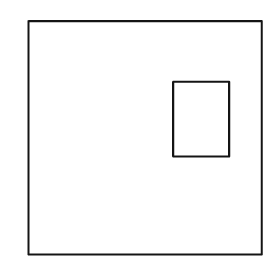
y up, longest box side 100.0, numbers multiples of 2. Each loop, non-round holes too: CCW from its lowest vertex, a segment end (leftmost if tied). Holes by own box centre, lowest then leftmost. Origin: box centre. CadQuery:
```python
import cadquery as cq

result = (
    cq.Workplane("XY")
    .moveTo(-50.0, -50.0)
    .lineTo(50.0, -50.0)
    .lineTo(50.0, 50.0)
    .lineTo(-50.0, 50.0)
    .close()
    .moveTo(12.0, -8.0)
    .lineTo(36.0, -8.0)
    .lineTo(36.0, 24.0)
    .lineTo(12.0, 24.0)
    .close()
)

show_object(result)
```